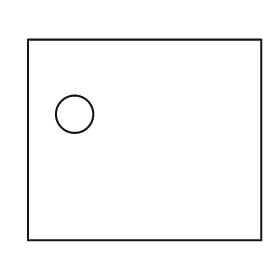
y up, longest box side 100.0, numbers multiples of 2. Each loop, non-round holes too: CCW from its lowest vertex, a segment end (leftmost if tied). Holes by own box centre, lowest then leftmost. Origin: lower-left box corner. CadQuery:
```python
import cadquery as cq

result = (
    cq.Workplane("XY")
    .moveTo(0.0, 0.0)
    .lineTo(100.0, 0.0)
    .lineTo(100.0, 86.0)
    .lineTo(0.0, 86.0)
    .close()
    .moveTo(20.0, 54.0)
    .circle(8.0)
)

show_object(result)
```